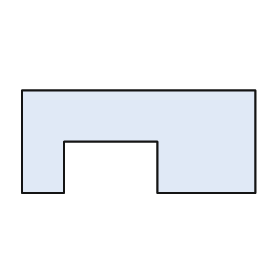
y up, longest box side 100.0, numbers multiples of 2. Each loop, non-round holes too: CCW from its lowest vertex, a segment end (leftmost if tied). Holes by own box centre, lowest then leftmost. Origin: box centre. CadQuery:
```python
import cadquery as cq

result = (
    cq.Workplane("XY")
    .moveTo(-50.0, -22.0)
    .lineTo(-32.0, -22.0)
    .lineTo(-32.0, 0.0)
    .lineTo(8.0, 0.0)
    .lineTo(8.0, -22.0)
    .lineTo(50.0, -22.0)
    .lineTo(50.0, 22.0)
    .lineTo(-50.0, 22.0)
    .close()
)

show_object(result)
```